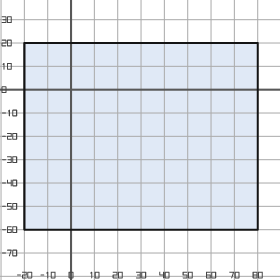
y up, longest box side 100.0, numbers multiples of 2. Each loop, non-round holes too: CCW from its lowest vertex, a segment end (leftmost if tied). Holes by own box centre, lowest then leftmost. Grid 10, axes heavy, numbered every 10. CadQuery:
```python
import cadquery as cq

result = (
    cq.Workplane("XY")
    .moveTo(-20.0, -60.0)
    .lineTo(80.0, -60.0)
    .lineTo(80.0, 20.0)
    .lineTo(-20.0, 20.0)
    .close()
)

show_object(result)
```